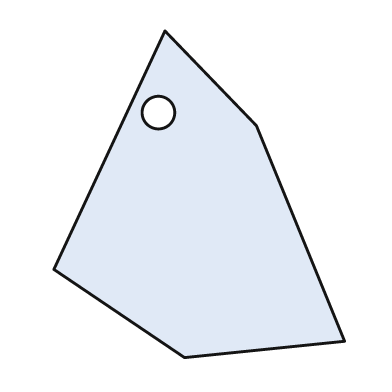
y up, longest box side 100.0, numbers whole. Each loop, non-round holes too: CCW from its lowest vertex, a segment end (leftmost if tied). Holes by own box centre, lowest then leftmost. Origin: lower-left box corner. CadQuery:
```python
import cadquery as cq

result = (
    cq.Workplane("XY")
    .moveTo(40.0, 0.0)
    .lineTo(89.0, 5.0)
    .lineTo(62.0, 71.0)
    .lineTo(34.0, 100.0)
    .lineTo(0.0, 27.0)
    .close()
    .moveTo(32.0, 75.0)
    .circle(5.0)
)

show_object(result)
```